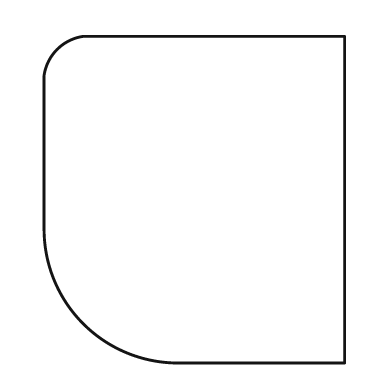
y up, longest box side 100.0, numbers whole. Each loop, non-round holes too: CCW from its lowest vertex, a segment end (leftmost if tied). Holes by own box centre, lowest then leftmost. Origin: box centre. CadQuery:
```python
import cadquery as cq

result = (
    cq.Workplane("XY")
    .moveTo(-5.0, -50.0)
    .lineTo(46.0, -50.0)
    .lineTo(46.0, 50.0)
    .lineTo(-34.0, 50.0)
    .threePointArc((-42.0, 46.0), (-46.0, 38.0))
    .lineTo(-46.0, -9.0)
    .threePointArc((-34.0, -38.0), (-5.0, -50.0))
    .close()
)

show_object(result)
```